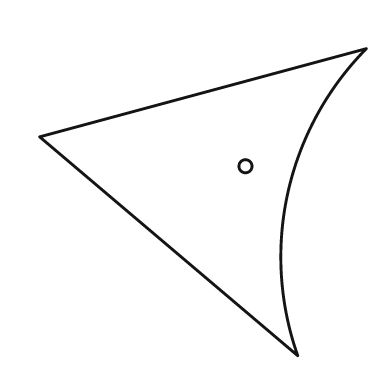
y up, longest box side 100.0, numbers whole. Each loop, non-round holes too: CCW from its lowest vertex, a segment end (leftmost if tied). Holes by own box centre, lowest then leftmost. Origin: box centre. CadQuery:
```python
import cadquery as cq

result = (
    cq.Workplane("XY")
    .moveTo(29.0, -47.0)
    .threePointArc((26.0, 3.0), (50.0, 47.0))
    .lineTo(-50.0, 20.0)
    .close()
    .moveTo(13.0, 11.0)
    .circle(2.0)
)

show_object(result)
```